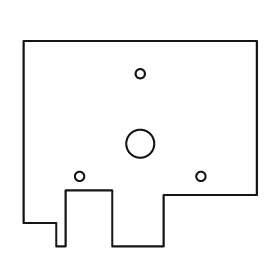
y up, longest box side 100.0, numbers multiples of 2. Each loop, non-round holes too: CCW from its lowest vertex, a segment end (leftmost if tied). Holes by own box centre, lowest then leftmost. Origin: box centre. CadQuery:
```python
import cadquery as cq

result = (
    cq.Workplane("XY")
    .moveTo(-36.0, -44.0)
    .lineTo(-32.0, -44.0)
    .lineTo(-32.0, -20.0)
    .lineTo(-12.0, -20.0)
    .lineTo(-12.0, -44.0)
    .lineTo(10.0, -44.0)
    .lineTo(10.0, -22.0)
    .lineTo(50.0, -22.0)
    .lineTo(50.0, 44.0)
    .lineTo(-50.0, 44.0)
    .lineTo(-50.0, -34.0)
    .lineTo(-36.0, -34.0)
    .close()
    .moveTo(-26.0, -14.0)
    .circle(2.0)
    .moveTo(26.0, -14.0)
    .circle(2.0)
    .moveTo(0.0, 0.0)
    .circle(6.0)
    .moveTo(0.0, 30.0)
    .circle(2.0)
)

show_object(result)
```